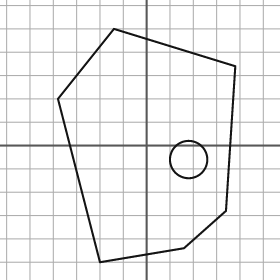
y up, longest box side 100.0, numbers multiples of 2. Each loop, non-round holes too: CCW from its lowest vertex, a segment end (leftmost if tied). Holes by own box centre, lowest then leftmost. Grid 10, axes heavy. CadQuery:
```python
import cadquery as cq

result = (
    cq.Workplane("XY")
    .moveTo(-20.0, -50.0)
    .lineTo(16.0, -44.0)
    .lineTo(34.0, -28.0)
    .lineTo(38.0, 34.0)
    .lineTo(-14.0, 50.0)
    .lineTo(-38.0, 20.0)
    .close()
    .moveTo(18.0, -6.0)
    .circle(8.0)
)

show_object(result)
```